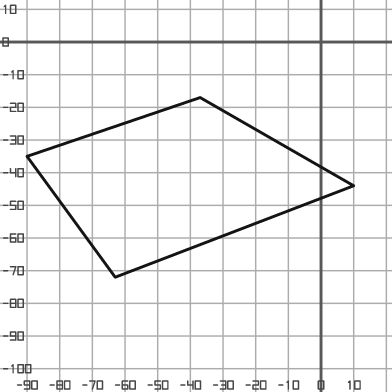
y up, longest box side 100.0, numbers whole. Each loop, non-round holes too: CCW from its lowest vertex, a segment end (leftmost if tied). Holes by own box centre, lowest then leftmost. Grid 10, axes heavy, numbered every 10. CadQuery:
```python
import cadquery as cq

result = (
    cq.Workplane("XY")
    .moveTo(-63.0, -72.0)
    .lineTo(10.0, -44.0)
    .lineTo(-37.0, -17.0)
    .lineTo(-90.0, -35.0)
    .close()
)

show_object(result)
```